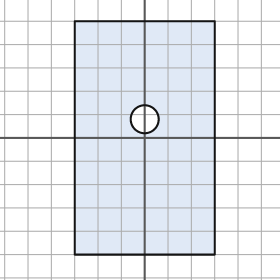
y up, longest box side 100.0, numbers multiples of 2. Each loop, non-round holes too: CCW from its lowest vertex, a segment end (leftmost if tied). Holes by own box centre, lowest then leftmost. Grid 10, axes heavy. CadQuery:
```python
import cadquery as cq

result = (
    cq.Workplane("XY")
    .moveTo(-30.0, -50.0)
    .lineTo(30.0, -50.0)
    .lineTo(30.0, 50.0)
    .lineTo(-30.0, 50.0)
    .close()
    .moveTo(0.0, 8.0)
    .circle(6.0)
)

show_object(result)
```